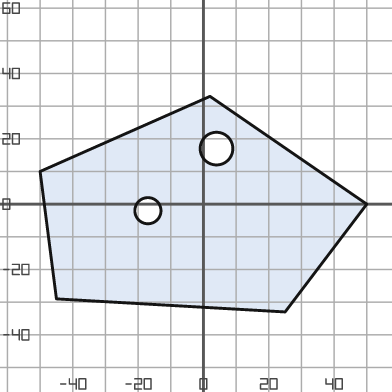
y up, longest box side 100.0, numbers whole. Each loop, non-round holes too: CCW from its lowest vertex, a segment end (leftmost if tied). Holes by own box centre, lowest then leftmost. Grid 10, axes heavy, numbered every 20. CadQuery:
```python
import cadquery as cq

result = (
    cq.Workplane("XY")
    .moveTo(25.0, -33.0)
    .lineTo(50.0, 0.0)
    .lineTo(2.0, 33.0)
    .lineTo(-50.0, 10.0)
    .lineTo(-45.0, -29.0)
    .close()
    .moveTo(-17.0, -2.0)
    .circle(4.0)
    .moveTo(4.0, 17.0)
    .circle(5.0)
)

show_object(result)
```